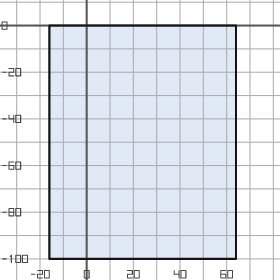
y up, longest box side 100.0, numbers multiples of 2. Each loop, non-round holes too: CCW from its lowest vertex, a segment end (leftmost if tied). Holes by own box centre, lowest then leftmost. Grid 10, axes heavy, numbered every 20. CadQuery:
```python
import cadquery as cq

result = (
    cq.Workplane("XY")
    .moveTo(-16.0, -100.0)
    .lineTo(64.0, -100.0)
    .lineTo(64.0, 0.0)
    .lineTo(-16.0, 0.0)
    .close()
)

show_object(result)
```